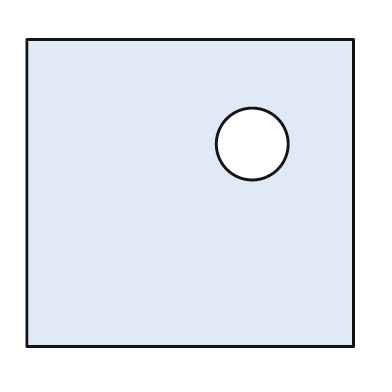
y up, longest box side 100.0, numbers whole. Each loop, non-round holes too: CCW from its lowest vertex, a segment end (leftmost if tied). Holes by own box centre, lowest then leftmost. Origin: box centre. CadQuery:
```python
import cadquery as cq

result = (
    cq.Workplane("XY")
    .moveTo(-50.0, -47.0)
    .lineTo(50.0, -47.0)
    .lineTo(50.0, 47.0)
    .lineTo(-50.0, 47.0)
    .close()
    .moveTo(19.0, 15.0)
    .circle(11.0)
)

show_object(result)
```